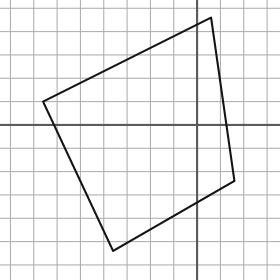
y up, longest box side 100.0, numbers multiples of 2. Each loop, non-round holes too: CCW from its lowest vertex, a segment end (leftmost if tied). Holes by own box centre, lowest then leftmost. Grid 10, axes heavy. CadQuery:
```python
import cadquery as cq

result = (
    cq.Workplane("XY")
    .moveTo(-36.0, -54.0)
    .lineTo(16.0, -24.0)
    .lineTo(6.0, 46.0)
    .lineTo(-66.0, 10.0)
    .close()
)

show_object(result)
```